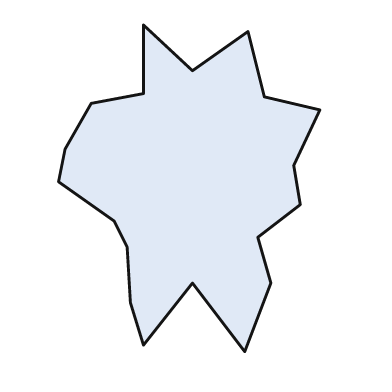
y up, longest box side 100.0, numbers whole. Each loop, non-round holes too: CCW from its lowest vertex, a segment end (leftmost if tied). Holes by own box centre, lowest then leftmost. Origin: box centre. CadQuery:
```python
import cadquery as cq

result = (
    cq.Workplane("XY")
    .moveTo(17.0, -50.0)
    .lineTo(25.0, -29.0)
    .lineTo(21.0, -15.0)
    .lineTo(34.0, -5.0)
    .lineTo(32.0, 7.0)
    .lineTo(40.0, 24.0)
    .lineTo(23.0, 28.0)
    .lineTo(18.0, 48.0)
    .lineTo(1.0, 36.0)
    .lineTo(-14.0, 50.0)
    .lineTo(-14.0, 29.0)
    .lineTo(-30.0, 26.0)
    .lineTo(-38.0, 12.0)
    .lineTo(-40.0, 2.0)
    .lineTo(-23.0, -10.0)
    .lineTo(-19.0, -18.0)
    .lineTo(-18.0, -35.0)
    .lineTo(-14.0, -48.0)
    .lineTo(1.0, -29.0)
    .close()
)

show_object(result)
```